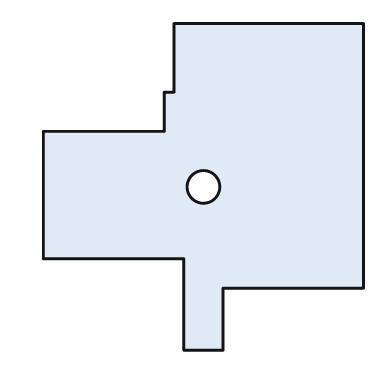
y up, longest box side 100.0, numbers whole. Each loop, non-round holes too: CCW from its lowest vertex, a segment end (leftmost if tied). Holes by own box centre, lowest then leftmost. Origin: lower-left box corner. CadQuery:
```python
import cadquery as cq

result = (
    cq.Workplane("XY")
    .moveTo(43.0, 0.0)
    .lineTo(55.0, 0.0)
    .lineTo(55.0, 19.0)
    .lineTo(98.0, 19.0)
    .lineTo(98.0, 100.0)
    .lineTo(40.0, 100.0)
    .lineTo(40.0, 79.0)
    .lineTo(37.0, 79.0)
    .lineTo(37.0, 67.0)
    .lineTo(0.0, 67.0)
    .lineTo(0.0, 28.0)
    .lineTo(43.0, 28.0)
    .close()
    .moveTo(49.0, 50.0)
    .circle(5.0)
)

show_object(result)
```